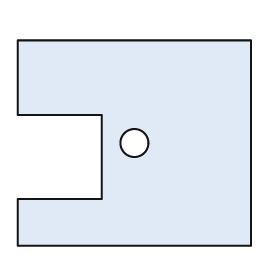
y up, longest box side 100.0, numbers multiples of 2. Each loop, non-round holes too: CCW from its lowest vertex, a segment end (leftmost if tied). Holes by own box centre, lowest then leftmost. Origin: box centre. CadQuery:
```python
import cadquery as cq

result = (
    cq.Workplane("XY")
    .moveTo(-50.0, -44.0)
    .lineTo(50.0, -44.0)
    .lineTo(50.0, 44.0)
    .lineTo(-50.0, 44.0)
    .lineTo(-50.0, 12.0)
    .lineTo(-14.0, 12.0)
    .lineTo(-14.0, -24.0)
    .lineTo(-50.0, -24.0)
    .close()
    .moveTo(0.0, 0.0)
    .circle(6.0)
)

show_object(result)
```